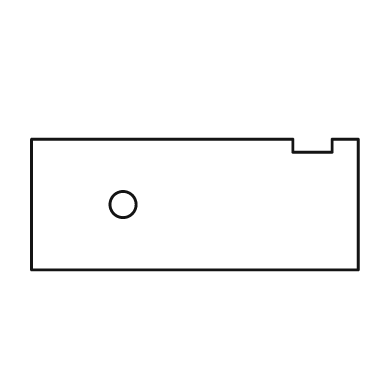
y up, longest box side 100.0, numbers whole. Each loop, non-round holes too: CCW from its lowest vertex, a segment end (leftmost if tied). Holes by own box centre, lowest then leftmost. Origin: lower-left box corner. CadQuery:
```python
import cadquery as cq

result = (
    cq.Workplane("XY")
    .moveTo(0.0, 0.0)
    .lineTo(100.0, 0.0)
    .lineTo(100.0, 40.0)
    .lineTo(92.0, 40.0)
    .lineTo(92.0, 36.0)
    .lineTo(80.0, 36.0)
    .lineTo(80.0, 40.0)
    .lineTo(0.0, 40.0)
    .close()
    .moveTo(28.0, 20.0)
    .circle(4.0)
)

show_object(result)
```